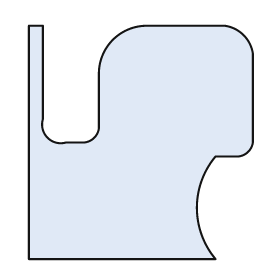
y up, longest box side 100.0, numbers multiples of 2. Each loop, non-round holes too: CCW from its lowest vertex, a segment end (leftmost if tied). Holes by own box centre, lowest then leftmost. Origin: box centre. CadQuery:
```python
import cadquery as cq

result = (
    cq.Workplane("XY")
    .moveTo(-48.0, -50.0)
    .lineTo(32.0, -50.0)
    .threePointArc((24.0, -28.0), (32.0, -6.0))
    .lineTo(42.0, -6.0)
    .threePointArc((46.0, -4.0), (48.0, 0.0))
    .lineTo(48.0, 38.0)
    .threePointArc((44.0, 46.0), (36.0, 50.0))
    .lineTo(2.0, 50.0)
    .threePointArc((-12.0, 44.0), (-18.0, 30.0))
    .lineTo(-18.0, 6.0)
    .threePointArc((-20.0, 2.0), (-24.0, 0.0))
    .lineTo(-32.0, 0.0)
    .threePointArc((-40.0, 2.0), (-42.0, 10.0))
    .lineTo(-42.0, 50.0)
    .lineTo(-48.0, 50.0)
    .close()
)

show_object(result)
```